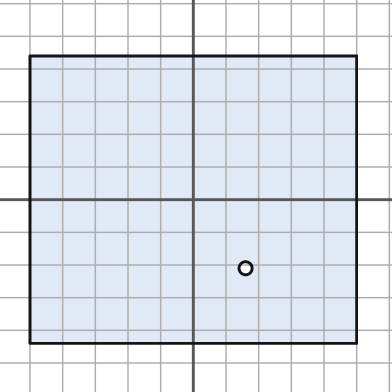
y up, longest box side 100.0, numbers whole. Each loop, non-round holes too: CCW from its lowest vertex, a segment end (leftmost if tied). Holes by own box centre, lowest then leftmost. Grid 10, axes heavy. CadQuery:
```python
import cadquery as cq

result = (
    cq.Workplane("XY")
    .moveTo(-50.0, -44.0)
    .lineTo(50.0, -44.0)
    .lineTo(50.0, 44.0)
    .lineTo(-50.0, 44.0)
    .close()
    .moveTo(16.0, -21.0)
    .circle(2.0)
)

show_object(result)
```